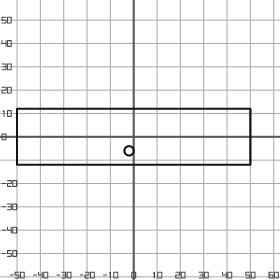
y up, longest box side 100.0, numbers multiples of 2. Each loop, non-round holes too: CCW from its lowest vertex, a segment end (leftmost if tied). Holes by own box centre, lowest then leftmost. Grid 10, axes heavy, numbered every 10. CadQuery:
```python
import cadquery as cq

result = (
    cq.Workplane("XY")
    .moveTo(-50.0, -12.0)
    .lineTo(50.0, -12.0)
    .lineTo(50.0, 12.0)
    .lineTo(-50.0, 12.0)
    .close()
    .moveTo(-2.0, -6.0)
    .circle(2.0)
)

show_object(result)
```